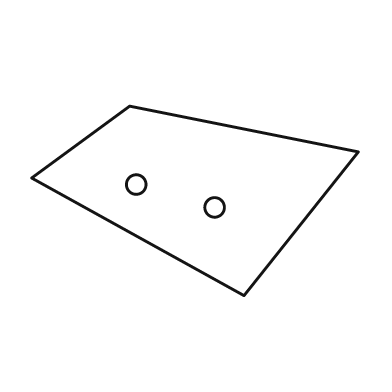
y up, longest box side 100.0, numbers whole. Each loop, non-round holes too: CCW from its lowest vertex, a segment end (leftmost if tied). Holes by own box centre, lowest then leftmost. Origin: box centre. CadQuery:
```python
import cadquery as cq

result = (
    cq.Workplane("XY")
    .moveTo(15.0, -29.0)
    .lineTo(50.0, 15.0)
    .lineTo(-20.0, 29.0)
    .lineTo(-50.0, 7.0)
    .close()
    .moveTo(6.0, -2.0)
    .circle(3.0)
    .moveTo(-18.0, 5.0)
    .circle(3.0)
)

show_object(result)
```